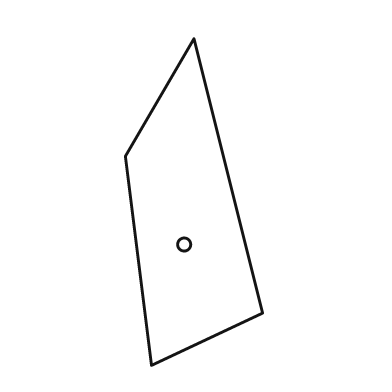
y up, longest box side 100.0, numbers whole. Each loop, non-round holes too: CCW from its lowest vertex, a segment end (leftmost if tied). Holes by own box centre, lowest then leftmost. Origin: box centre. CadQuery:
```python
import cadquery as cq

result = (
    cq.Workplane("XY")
    .moveTo(-13.0, -50.0)
    .lineTo(21.0, -34.0)
    .lineTo(0.0, 50.0)
    .lineTo(-21.0, 14.0)
    .close()
    .moveTo(-3.0, -13.0)
    .circle(2.0)
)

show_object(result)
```